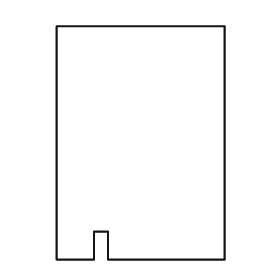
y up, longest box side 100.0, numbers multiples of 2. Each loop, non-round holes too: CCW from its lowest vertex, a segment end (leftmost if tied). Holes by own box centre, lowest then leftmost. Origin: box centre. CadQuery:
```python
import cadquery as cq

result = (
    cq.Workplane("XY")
    .moveTo(-36.0, -50.0)
    .lineTo(-20.0, -50.0)
    .lineTo(-20.0, -38.0)
    .lineTo(-14.0, -38.0)
    .lineTo(-14.0, -50.0)
    .lineTo(36.0, -50.0)
    .lineTo(36.0, 50.0)
    .lineTo(-36.0, 50.0)
    .close()
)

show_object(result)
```